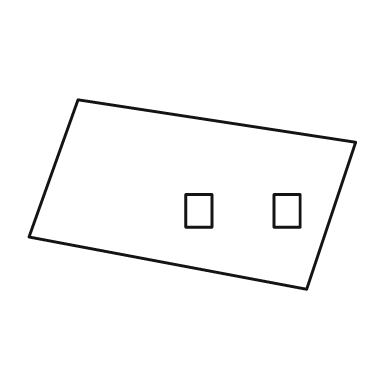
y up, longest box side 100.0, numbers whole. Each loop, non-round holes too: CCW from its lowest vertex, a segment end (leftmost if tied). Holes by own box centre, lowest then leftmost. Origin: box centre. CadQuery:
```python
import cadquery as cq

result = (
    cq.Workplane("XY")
    .moveTo(35.0, -29.0)
    .lineTo(50.0, 16.0)
    .lineTo(-35.0, 29.0)
    .lineTo(-50.0, -13.0)
    .close()
    .moveTo(-2.0, -10.0)
    .lineTo(6.0, -10.0)
    .lineTo(6.0, 0.0)
    .lineTo(-2.0, 0.0)
    .close()
    .moveTo(25.0, -10.0)
    .lineTo(33.0, -10.0)
    .lineTo(33.0, 0.0)
    .lineTo(25.0, 0.0)
    .close()
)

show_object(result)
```